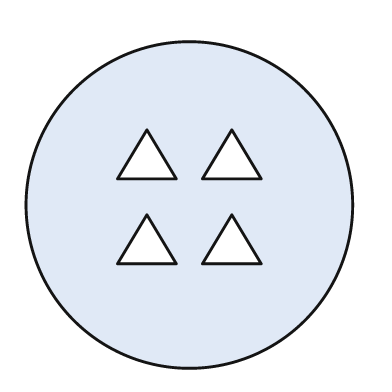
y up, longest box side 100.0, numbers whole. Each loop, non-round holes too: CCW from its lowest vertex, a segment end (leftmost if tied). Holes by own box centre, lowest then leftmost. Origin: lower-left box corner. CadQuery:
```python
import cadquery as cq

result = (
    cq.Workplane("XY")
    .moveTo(50.0, 50.0)
    .circle(50.0)
    .moveTo(28.0, 32.0)
    .lineTo(46.0, 32.0)
    .lineTo(37.0, 47.0)
    .close()
    .moveTo(54.0, 32.0)
    .lineTo(72.0, 32.0)
    .lineTo(63.0, 47.0)
    .close()
    .moveTo(28.0, 58.0)
    .lineTo(46.0, 58.0)
    .lineTo(37.0, 73.0)
    .close()
    .moveTo(54.0, 58.0)
    .lineTo(72.0, 58.0)
    .lineTo(63.0, 73.0)
    .close()
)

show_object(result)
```